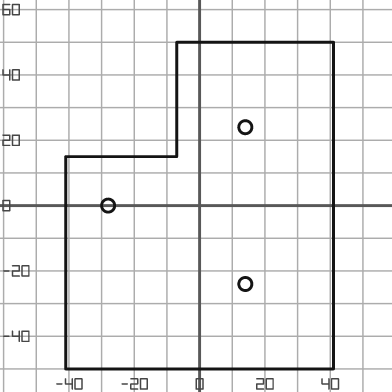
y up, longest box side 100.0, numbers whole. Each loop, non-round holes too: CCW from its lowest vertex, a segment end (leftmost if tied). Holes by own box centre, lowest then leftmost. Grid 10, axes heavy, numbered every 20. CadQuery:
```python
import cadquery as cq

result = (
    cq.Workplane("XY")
    .moveTo(-41.0, -50.0)
    .lineTo(41.0, -50.0)
    .lineTo(41.0, 50.0)
    .lineTo(-7.0, 50.0)
    .lineTo(-7.0, 15.0)
    .lineTo(-41.0, 15.0)
    .close()
    .moveTo(14.0, -24.0)
    .circle(2.0)
    .moveTo(-28.0, 0.0)
    .circle(2.0)
    .moveTo(14.0, 24.0)
    .circle(2.0)
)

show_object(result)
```